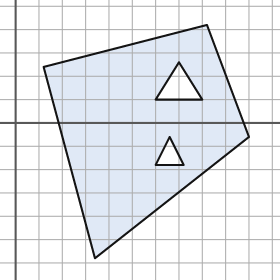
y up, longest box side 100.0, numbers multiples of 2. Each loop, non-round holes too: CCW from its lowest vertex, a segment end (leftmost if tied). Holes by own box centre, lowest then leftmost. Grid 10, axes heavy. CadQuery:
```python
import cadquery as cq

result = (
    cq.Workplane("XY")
    .moveTo(34.0, -58.0)
    .lineTo(100.0, -6.0)
    .lineTo(82.0, 42.0)
    .lineTo(12.0, 24.0)
    .close()
    .moveTo(60.0, -18.0)
    .lineTo(72.0, -18.0)
    .lineTo(66.0, -6.0)
    .close()
    .moveTo(60.0, 10.0)
    .lineTo(80.0, 10.0)
    .lineTo(70.0, 26.0)
    .close()
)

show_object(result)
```